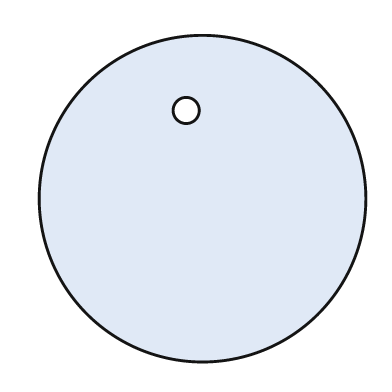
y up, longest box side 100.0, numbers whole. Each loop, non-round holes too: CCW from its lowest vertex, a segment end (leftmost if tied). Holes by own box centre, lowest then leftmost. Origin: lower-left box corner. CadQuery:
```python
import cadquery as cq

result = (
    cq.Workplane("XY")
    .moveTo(50.0, 50.0)
    .circle(50.0)
    .moveTo(45.0, 77.0)
    .circle(4.0)
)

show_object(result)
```